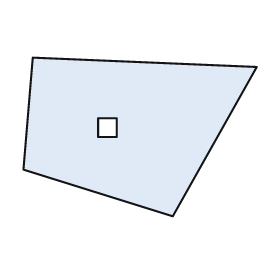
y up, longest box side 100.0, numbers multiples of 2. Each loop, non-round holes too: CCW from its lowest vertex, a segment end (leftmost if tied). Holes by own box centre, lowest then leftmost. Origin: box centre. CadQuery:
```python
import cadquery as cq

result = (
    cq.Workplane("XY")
    .moveTo(14.0, -34.0)
    .lineTo(50.0, 30.0)
    .lineTo(-46.0, 34.0)
    .lineTo(-50.0, -14.0)
    .close()
    .moveTo(-18.0, 0.0)
    .lineTo(-10.0, 0.0)
    .lineTo(-10.0, 8.0)
    .lineTo(-18.0, 8.0)
    .close()
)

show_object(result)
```